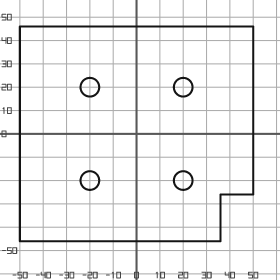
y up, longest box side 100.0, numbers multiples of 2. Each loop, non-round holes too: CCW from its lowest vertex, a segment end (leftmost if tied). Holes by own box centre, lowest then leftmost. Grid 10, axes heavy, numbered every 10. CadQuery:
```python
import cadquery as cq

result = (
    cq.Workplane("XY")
    .moveTo(-50.0, -46.0)
    .lineTo(36.0, -46.0)
    .lineTo(36.0, -26.0)
    .lineTo(50.0, -26.0)
    .lineTo(50.0, 46.0)
    .lineTo(-50.0, 46.0)
    .close()
    .moveTo(-20.0, -20.0)
    .circle(4.0)
    .moveTo(20.0, -20.0)
    .circle(4.0)
    .moveTo(-20.0, 20.0)
    .circle(4.0)
    .moveTo(20.0, 20.0)
    .circle(4.0)
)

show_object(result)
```